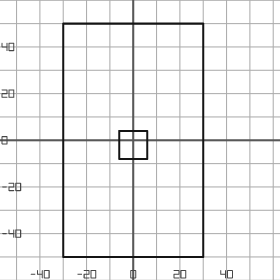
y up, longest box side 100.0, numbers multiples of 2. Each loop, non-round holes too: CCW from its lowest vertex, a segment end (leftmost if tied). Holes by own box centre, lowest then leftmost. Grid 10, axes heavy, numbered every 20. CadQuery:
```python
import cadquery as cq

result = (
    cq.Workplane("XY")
    .moveTo(-30.0, -50.0)
    .lineTo(30.0, -50.0)
    .lineTo(30.0, 50.0)
    .lineTo(-30.0, 50.0)
    .close()
    .moveTo(-6.0, -8.0)
    .lineTo(6.0, -8.0)
    .lineTo(6.0, 4.0)
    .lineTo(-6.0, 4.0)
    .close()
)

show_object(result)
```